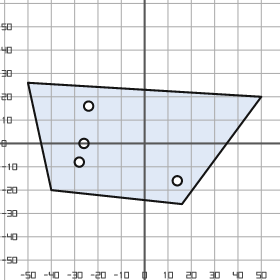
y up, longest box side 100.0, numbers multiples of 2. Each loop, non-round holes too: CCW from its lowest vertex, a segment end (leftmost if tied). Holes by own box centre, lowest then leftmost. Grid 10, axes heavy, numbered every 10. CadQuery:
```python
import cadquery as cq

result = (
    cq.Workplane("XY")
    .moveTo(16.0, -26.0)
    .lineTo(50.0, 20.0)
    .lineTo(-50.0, 26.0)
    .lineTo(-40.0, -20.0)
    .close()
    .moveTo(14.0, -16.0)
    .circle(2.0)
    .moveTo(-28.0, -8.0)
    .circle(2.0)
    .moveTo(-26.0, 0.0)
    .circle(2.0)
    .moveTo(-24.0, 16.0)
    .circle(2.0)
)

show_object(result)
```